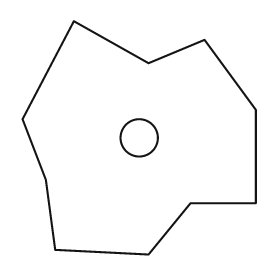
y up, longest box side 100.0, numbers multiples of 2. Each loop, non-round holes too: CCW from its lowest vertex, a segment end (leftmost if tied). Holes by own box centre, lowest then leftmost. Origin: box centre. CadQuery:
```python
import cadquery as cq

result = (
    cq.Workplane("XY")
    .moveTo(4.0, -50.0)
    .lineTo(22.0, -28.0)
    .lineTo(50.0, -28.0)
    .lineTo(50.0, 12.0)
    .lineTo(28.0, 42.0)
    .lineTo(4.0, 32.0)
    .lineTo(-28.0, 50.0)
    .lineTo(-50.0, 8.0)
    .lineTo(-40.0, -18.0)
    .lineTo(-36.0, -48.0)
    .close()
    .moveTo(0.0, 0.0)
    .circle(8.0)
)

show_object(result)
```